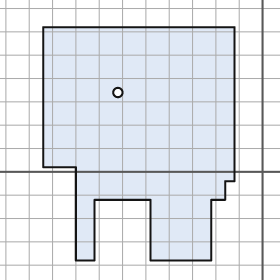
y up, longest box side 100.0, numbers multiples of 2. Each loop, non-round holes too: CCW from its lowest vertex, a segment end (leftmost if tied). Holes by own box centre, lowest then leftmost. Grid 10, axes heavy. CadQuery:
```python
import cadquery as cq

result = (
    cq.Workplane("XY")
    .moveTo(-80.0, -38.0)
    .lineTo(-72.0, -38.0)
    .lineTo(-72.0, -12.0)
    .lineTo(-48.0, -12.0)
    .lineTo(-48.0, -38.0)
    .lineTo(-22.0, -38.0)
    .lineTo(-22.0, -12.0)
    .lineTo(-16.0, -12.0)
    .lineTo(-16.0, -4.0)
    .lineTo(-12.0, -4.0)
    .lineTo(-12.0, 62.0)
    .lineTo(-94.0, 62.0)
    .lineTo(-94.0, 2.0)
    .lineTo(-80.0, 2.0)
    .close()
    .moveTo(-62.0, 34.0)
    .circle(2.0)
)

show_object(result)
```